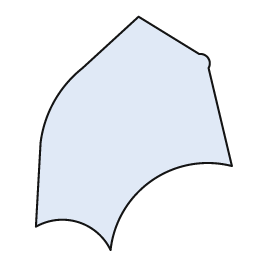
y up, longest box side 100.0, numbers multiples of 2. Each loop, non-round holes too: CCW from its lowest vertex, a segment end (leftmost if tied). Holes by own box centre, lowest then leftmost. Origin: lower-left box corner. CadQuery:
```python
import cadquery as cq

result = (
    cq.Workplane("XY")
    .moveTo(32.0, 0.0)
    .threePointArc((50.0, 30.0), (84.0, 36.0))
    .lineTo(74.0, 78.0)
    .threePointArc((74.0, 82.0), (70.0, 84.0))
    .lineTo(44.0, 100.0)
    .lineTo(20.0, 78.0)
    .threePointArc((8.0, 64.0), (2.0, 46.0))
    .lineTo(0.0, 10.0)
    .threePointArc((18.0, 12.0), (32.0, 0.0))
    .close()
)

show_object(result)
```